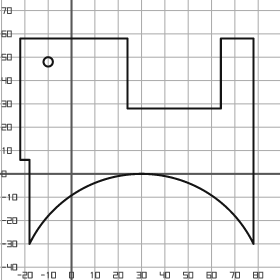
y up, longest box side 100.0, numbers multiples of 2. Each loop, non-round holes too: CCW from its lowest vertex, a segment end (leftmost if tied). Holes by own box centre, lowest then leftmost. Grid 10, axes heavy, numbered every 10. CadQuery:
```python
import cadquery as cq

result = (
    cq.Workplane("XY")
    .moveTo(-18.0, -30.0)
    .threePointArc((30.0, 0.0), (78.0, -30.0))
    .lineTo(78.0, 58.0)
    .lineTo(64.0, 58.0)
    .lineTo(64.0, 28.0)
    .lineTo(24.0, 28.0)
    .lineTo(24.0, 58.0)
    .lineTo(-22.0, 58.0)
    .lineTo(-22.0, 6.0)
    .lineTo(-18.0, 6.0)
    .close()
    .moveTo(-10.0, 48.0)
    .circle(2.0)
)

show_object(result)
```